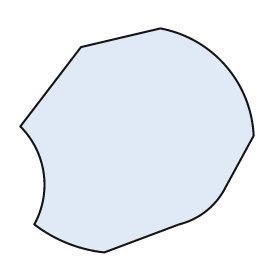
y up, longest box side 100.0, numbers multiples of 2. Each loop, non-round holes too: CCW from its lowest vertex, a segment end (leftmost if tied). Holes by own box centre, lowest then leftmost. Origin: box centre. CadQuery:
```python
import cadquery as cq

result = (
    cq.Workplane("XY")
    .moveTo(-14.0, -48.0)
    .lineTo(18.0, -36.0)
    .threePointArc((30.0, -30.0), (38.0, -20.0))
    .lineTo(50.0, 2.0)
    .threePointArc((38.0, 32.0), (10.0, 48.0))
    .lineTo(-24.0, 40.0)
    .lineTo(-50.0, 6.0)
    .threePointArc((-40.0, -14.0), (-44.0, -36.0))
    .threePointArc((-30.0, -44.0), (-14.0, -48.0))
    .close()
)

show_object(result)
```